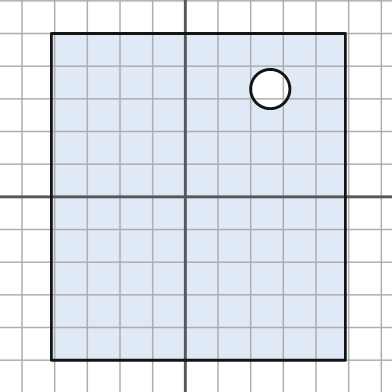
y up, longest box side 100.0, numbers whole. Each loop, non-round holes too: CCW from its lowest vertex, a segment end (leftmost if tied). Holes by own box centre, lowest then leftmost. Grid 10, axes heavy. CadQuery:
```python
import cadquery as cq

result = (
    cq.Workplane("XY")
    .moveTo(-41.0, -50.0)
    .lineTo(49.0, -50.0)
    .lineTo(49.0, 50.0)
    .lineTo(-41.0, 50.0)
    .close()
    .moveTo(26.0, 33.0)
    .circle(6.0)
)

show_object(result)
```